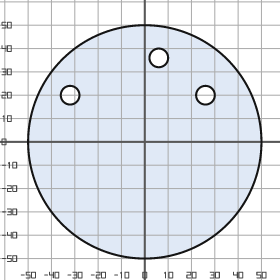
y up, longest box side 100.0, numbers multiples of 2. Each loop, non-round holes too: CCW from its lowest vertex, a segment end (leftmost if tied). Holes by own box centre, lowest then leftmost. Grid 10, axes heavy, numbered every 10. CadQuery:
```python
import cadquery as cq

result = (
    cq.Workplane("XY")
    .moveTo(0.0, 0.0)
    .circle(50.0)
    .moveTo(-32.0, 20.0)
    .circle(4.0)
    .moveTo(26.0, 20.0)
    .circle(4.0)
    .moveTo(6.0, 36.0)
    .circle(4.0)
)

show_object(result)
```